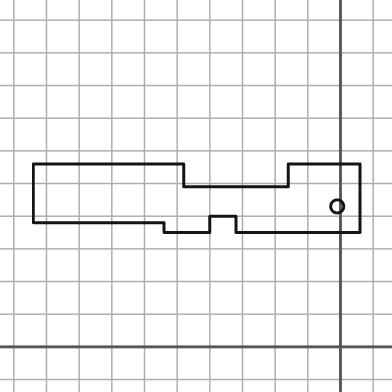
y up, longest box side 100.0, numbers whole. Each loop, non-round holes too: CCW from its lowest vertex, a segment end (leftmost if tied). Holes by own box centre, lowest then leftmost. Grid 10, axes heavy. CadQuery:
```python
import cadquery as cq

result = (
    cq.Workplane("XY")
    .moveTo(-54.0, 35.0)
    .lineTo(-40.0, 35.0)
    .lineTo(-40.0, 40.0)
    .lineTo(-32.0, 40.0)
    .lineTo(-32.0, 35.0)
    .lineTo(6.0, 35.0)
    .lineTo(6.0, 56.0)
    .lineTo(-16.0, 56.0)
    .lineTo(-16.0, 49.0)
    .lineTo(-48.0, 49.0)
    .lineTo(-48.0, 56.0)
    .lineTo(-94.0, 56.0)
    .lineTo(-94.0, 38.0)
    .lineTo(-54.0, 38.0)
    .close()
    .moveTo(-1.0, 43.0)
    .circle(2.0)
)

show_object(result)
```